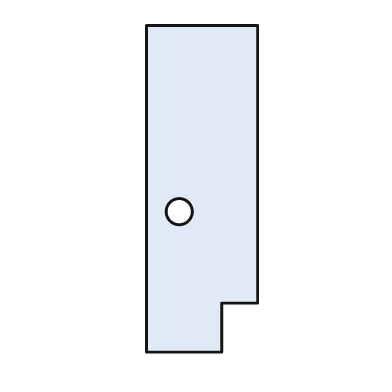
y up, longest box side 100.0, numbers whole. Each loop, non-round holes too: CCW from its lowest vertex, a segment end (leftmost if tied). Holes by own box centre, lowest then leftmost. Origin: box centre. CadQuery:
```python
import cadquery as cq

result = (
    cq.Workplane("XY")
    .moveTo(-17.0, -50.0)
    .lineTo(6.0, -50.0)
    .lineTo(6.0, -35.0)
    .lineTo(17.0, -35.0)
    .lineTo(17.0, 50.0)
    .lineTo(-17.0, 50.0)
    .close()
    .moveTo(-7.0, -7.0)
    .circle(4.0)
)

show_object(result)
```